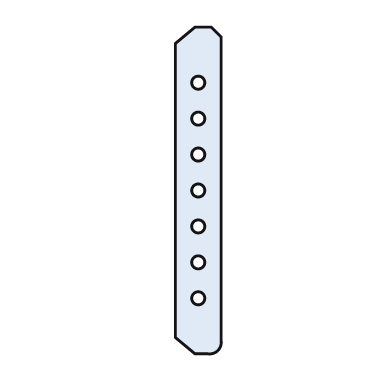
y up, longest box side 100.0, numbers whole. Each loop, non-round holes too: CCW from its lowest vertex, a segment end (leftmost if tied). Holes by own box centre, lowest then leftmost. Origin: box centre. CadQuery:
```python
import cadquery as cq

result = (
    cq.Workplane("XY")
    .moveTo(-1.0, -50.0)
    .lineTo(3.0, -50.0)
    .threePointArc((6.0, -49.0), (7.0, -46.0))
    .lineTo(7.0, 47.0)
    .lineTo(4.0, 50.0)
    .lineTo(-1.0, 50.0)
    .lineTo(-7.0, 45.0)
    .lineTo(-7.0, -45.0)
    .close()
    .moveTo(0.0, -33.0)
    .circle(2.0)
    .moveTo(0.0, -22.0)
    .circle(2.0)
    .moveTo(0.0, -11.0)
    .circle(2.0)
    .moveTo(0.0, 0.0)
    .circle(2.0)
    .moveTo(0.0, 11.0)
    .circle(2.0)
    .moveTo(0.0, 22.0)
    .circle(2.0)
    .moveTo(0.0, 33.0)
    .circle(2.0)
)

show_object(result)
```